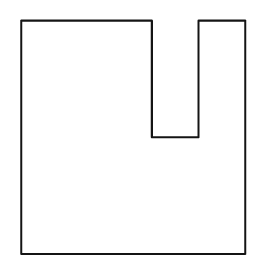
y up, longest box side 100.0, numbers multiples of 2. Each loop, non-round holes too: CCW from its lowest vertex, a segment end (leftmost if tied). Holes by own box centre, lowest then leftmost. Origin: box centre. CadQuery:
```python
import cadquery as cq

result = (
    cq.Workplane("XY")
    .moveTo(-48.0, -50.0)
    .lineTo(48.0, -50.0)
    .lineTo(48.0, 50.0)
    .lineTo(28.0, 50.0)
    .lineTo(28.0, 0.0)
    .lineTo(8.0, 0.0)
    .lineTo(8.0, 50.0)
    .lineTo(-48.0, 50.0)
    .close()
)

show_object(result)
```